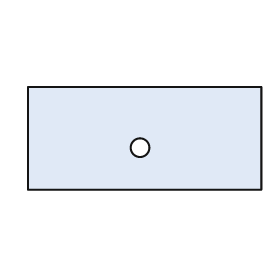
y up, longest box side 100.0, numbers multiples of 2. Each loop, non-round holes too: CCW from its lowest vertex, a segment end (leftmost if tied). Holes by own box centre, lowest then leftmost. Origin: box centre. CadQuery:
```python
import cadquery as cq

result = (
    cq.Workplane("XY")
    .moveTo(-50.0, -22.0)
    .lineTo(50.0, -22.0)
    .lineTo(50.0, 22.0)
    .lineTo(-50.0, 22.0)
    .close()
    .moveTo(-2.0, -4.0)
    .circle(4.0)
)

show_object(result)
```